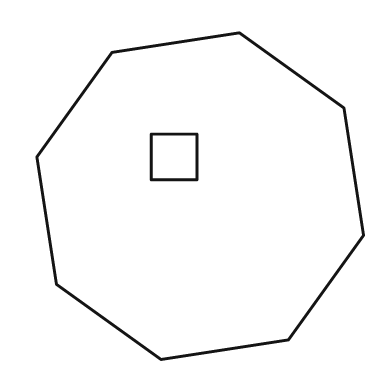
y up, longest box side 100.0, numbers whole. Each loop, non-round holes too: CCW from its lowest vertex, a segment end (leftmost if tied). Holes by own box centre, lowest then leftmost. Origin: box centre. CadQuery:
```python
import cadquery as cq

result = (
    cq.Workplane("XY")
    .moveTo(-12.0, -50.0)
    .lineTo(27.0, -44.0)
    .lineTo(50.0, -12.0)
    .lineTo(44.0, 27.0)
    .lineTo(12.0, 50.0)
    .lineTo(-27.0, 44.0)
    .lineTo(-50.0, 12.0)
    .lineTo(-44.0, -27.0)
    .close()
    .moveTo(-15.0, 5.0)
    .lineTo(-1.0, 5.0)
    .lineTo(-1.0, 19.0)
    .lineTo(-15.0, 19.0)
    .close()
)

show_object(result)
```